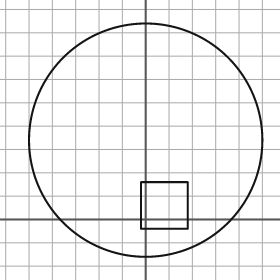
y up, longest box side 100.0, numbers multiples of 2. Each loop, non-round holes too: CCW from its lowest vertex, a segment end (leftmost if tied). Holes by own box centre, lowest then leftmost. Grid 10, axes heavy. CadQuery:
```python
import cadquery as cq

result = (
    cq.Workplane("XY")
    .moveTo(0.0, 34.0)
    .circle(50.0)
    .moveTo(-2.0, -4.0)
    .lineTo(18.0, -4.0)
    .lineTo(18.0, 16.0)
    .lineTo(-2.0, 16.0)
    .close()
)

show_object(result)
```